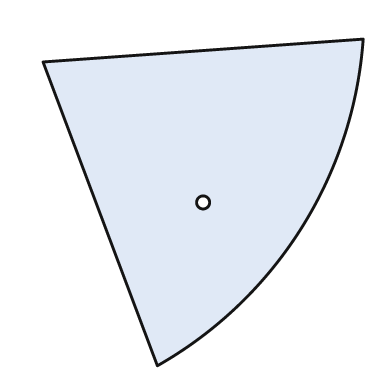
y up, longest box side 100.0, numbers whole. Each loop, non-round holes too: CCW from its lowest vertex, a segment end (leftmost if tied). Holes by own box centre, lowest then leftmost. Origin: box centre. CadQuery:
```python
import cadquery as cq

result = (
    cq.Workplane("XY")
    .moveTo(-14.0, -50.0)
    .threePointArc((30.0, -8.0), (49.0, 50.0))
    .lineTo(-49.0, 43.0)
    .close()
    .moveTo(0.0, 0.0)
    .circle(2.0)
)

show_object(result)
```